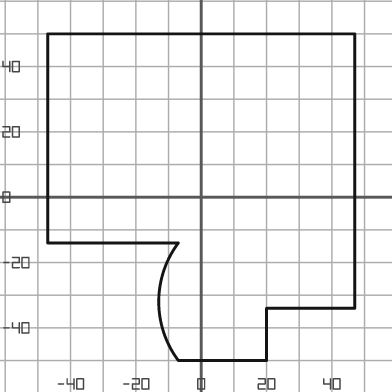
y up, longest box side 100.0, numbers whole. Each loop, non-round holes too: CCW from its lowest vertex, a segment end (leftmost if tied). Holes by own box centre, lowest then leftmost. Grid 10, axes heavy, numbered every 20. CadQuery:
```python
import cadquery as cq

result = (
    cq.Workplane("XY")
    .moveTo(-7.0, -50.0)
    .lineTo(20.0, -50.0)
    .lineTo(20.0, -34.0)
    .lineTo(47.0, -34.0)
    .lineTo(47.0, 50.0)
    .lineTo(-47.0, 50.0)
    .lineTo(-47.0, -14.0)
    .lineTo(-7.0, -14.0)
    .threePointArc((-13.0, -32.0), (-7.0, -50.0))
    .close()
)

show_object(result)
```